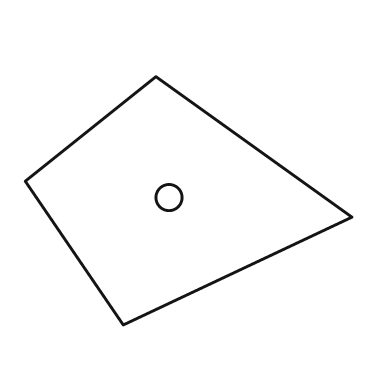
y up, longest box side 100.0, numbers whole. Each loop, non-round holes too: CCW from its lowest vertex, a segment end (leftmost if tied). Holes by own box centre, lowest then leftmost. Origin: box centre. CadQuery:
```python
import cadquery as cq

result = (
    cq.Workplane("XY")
    .moveTo(-20.0, -38.0)
    .lineTo(50.0, -5.0)
    .lineTo(-10.0, 38.0)
    .lineTo(-50.0, 6.0)
    .close()
    .moveTo(-6.0, 1.0)
    .circle(4.0)
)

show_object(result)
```